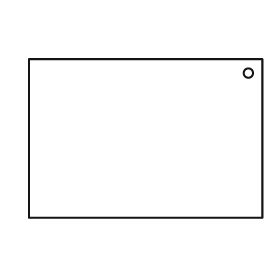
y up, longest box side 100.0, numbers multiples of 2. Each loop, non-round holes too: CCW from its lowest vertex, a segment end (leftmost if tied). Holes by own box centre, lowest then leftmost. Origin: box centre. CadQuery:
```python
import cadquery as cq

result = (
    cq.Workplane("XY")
    .moveTo(-50.0, -34.0)
    .lineTo(50.0, -34.0)
    .lineTo(50.0, 34.0)
    .lineTo(-50.0, 34.0)
    .close()
    .moveTo(44.0, 28.0)
    .circle(2.0)
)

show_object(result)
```